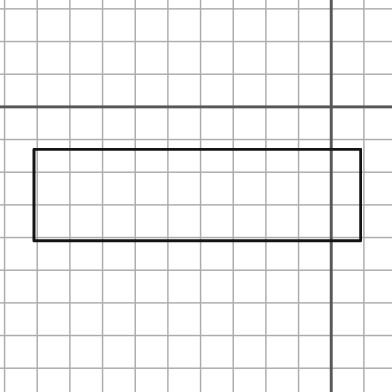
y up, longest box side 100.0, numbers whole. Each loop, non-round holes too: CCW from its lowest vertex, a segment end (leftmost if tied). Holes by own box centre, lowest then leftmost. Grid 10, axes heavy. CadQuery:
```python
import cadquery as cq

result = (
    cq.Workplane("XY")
    .moveTo(-91.0, -41.0)
    .lineTo(9.0, -41.0)
    .lineTo(9.0, -13.0)
    .lineTo(-91.0, -13.0)
    .close()
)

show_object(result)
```